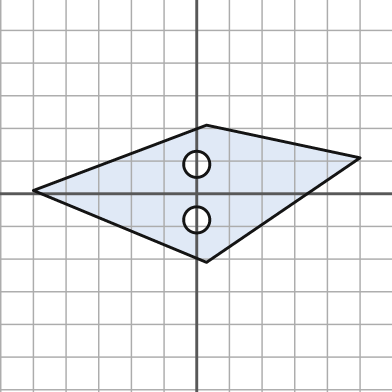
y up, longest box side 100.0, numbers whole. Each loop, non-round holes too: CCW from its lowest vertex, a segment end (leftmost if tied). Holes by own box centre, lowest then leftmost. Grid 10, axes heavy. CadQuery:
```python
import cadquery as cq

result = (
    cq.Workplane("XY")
    .moveTo(3.0, -21.0)
    .lineTo(50.0, 11.0)
    .lineTo(3.0, 21.0)
    .lineTo(-50.0, 1.0)
    .close()
    .moveTo(0.0, -8.0)
    .circle(4.0)
    .moveTo(0.0, 9.0)
    .circle(4.0)
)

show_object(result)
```